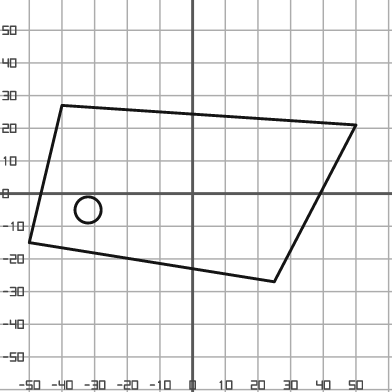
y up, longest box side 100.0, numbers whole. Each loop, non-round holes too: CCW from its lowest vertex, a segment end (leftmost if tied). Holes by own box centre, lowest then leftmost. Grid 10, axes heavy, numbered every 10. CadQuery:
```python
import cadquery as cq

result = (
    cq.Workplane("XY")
    .moveTo(25.0, -27.0)
    .lineTo(50.0, 21.0)
    .lineTo(-40.0, 27.0)
    .lineTo(-50.0, -15.0)
    .close()
    .moveTo(-32.0, -5.0)
    .circle(4.0)
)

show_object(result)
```